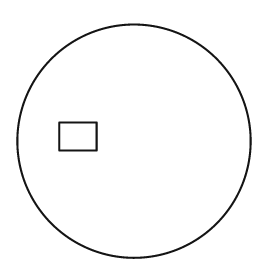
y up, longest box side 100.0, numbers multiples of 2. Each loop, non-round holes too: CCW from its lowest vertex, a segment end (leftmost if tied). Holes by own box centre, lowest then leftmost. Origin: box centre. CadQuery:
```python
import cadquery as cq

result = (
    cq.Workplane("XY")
    .moveTo(0.0, 0.0)
    .circle(50.0)
    .moveTo(-32.0, -4.0)
    .lineTo(-16.0, -4.0)
    .lineTo(-16.0, 8.0)
    .lineTo(-32.0, 8.0)
    .close()
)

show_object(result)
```